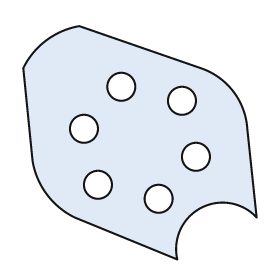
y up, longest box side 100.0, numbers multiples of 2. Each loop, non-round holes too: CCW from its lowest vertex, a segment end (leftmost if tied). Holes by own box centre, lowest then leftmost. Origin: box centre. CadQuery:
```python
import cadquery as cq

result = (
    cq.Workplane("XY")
    .moveTo(16.0, -50.0)
    .threePointArc((26.0, -28.0), (50.0, -32.0))
    .lineTo(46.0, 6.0)
    .threePointArc((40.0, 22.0), (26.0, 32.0))
    .lineTo(-26.0, 50.0)
    .threePointArc((-40.0, 44.0), (-50.0, 32.0))
    .lineTo(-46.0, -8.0)
    .threePointArc((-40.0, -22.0), (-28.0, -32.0))
    .close()
    .moveTo(8.0, -24.0)
    .circle(6.0)
    .moveTo(-18.0, -18.0)
    .circle(6.0)
    .moveTo(24.0, -6.0)
    .circle(6.0)
    .moveTo(-24.0, 6.0)
    .circle(6.0)
    .moveTo(18.0, 18.0)
    .circle(6.0)
    .moveTo(-8.0, 24.0)
    .circle(6.0)
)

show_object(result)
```